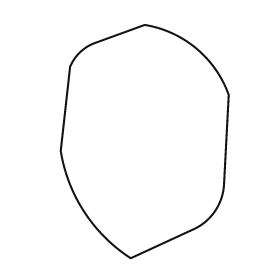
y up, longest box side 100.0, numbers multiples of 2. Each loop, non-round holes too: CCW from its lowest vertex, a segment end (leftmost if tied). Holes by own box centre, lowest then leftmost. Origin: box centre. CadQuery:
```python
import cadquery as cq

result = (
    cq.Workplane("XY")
    .moveTo(-6.0, -50.0)
    .lineTo(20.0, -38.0)
    .threePointArc((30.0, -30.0), (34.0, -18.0))
    .lineTo(36.0, 20.0)
    .threePointArc((22.0, 40.0), (0.0, 50.0))
    .lineTo(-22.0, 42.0)
    .threePointArc((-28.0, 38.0), (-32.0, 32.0))
    .lineTo(-36.0, -4.0)
    .threePointArc((-26.0, -30.0), (-6.0, -50.0))
    .close()
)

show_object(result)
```